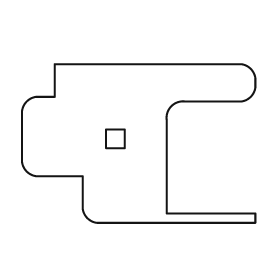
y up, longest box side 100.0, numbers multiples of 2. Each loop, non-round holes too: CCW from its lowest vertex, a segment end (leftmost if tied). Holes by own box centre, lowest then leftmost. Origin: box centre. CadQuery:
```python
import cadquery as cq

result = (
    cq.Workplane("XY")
    .moveTo(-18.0, -34.0)
    .lineTo(50.0, -34.0)
    .lineTo(50.0, -30.0)
    .lineTo(12.0, -30.0)
    .lineTo(12.0, 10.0)
    .threePointArc((14.0, 16.0), (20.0, 18.0))
    .lineTo(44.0, 18.0)
    .threePointArc((48.0, 20.0), (50.0, 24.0))
    .lineTo(50.0, 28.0)
    .threePointArc((48.0, 32.0), (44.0, 34.0))
    .lineTo(-36.0, 34.0)
    .lineTo(-36.0, 20.0)
    .lineTo(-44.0, 20.0)
    .threePointArc((-48.0, 18.0), (-50.0, 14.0))
    .lineTo(-50.0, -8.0)
    .threePointArc((-48.0, -12.0), (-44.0, -14.0))
    .lineTo(-24.0, -14.0)
    .lineTo(-24.0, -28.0)
    .threePointArc((-22.0, -32.0), (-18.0, -34.0))
    .close()
    .moveTo(-14.0, -2.0)
    .lineTo(-6.0, -2.0)
    .lineTo(-6.0, 6.0)
    .lineTo(-14.0, 6.0)
    .close()
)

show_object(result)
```